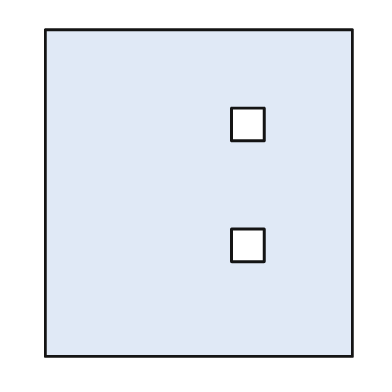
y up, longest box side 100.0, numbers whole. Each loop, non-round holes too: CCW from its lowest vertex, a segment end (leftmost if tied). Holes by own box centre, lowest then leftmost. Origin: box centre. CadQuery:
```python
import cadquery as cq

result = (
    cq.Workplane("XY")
    .moveTo(-47.0, -50.0)
    .lineTo(47.0, -50.0)
    .lineTo(47.0, 50.0)
    .lineTo(-47.0, 50.0)
    .close()
    .moveTo(10.0, -21.0)
    .lineTo(20.0, -21.0)
    .lineTo(20.0, -11.0)
    .lineTo(10.0, -11.0)
    .close()
    .moveTo(10.0, 16.0)
    .lineTo(20.0, 16.0)
    .lineTo(20.0, 26.0)
    .lineTo(10.0, 26.0)
    .close()
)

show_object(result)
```